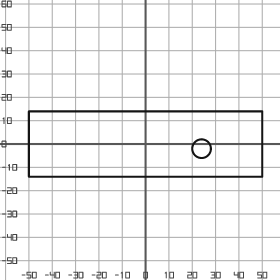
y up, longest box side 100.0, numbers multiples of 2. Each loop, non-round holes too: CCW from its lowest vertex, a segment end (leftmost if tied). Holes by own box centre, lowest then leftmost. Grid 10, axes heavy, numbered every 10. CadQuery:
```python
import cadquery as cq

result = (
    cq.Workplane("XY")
    .moveTo(-50.0, -14.0)
    .lineTo(50.0, -14.0)
    .lineTo(50.0, 14.0)
    .lineTo(-50.0, 14.0)
    .close()
    .moveTo(24.0, -2.0)
    .circle(4.0)
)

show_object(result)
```